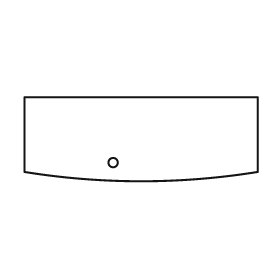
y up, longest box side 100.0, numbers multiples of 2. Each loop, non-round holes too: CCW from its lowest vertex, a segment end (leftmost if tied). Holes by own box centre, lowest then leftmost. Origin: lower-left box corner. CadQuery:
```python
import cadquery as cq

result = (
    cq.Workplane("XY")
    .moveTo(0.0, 4.0)
    .threePointArc((50.0, 0.0), (100.0, 4.0))
    .lineTo(100.0, 36.0)
    .lineTo(0.0, 36.0)
    .close()
    .moveTo(38.0, 8.0)
    .circle(2.0)
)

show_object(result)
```